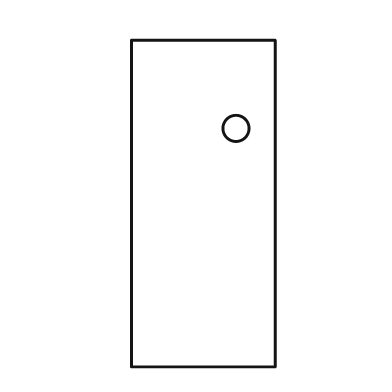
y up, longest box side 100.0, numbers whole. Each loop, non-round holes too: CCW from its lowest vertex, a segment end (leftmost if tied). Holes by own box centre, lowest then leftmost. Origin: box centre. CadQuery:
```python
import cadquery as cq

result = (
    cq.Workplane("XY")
    .moveTo(-22.0, -50.0)
    .lineTo(22.0, -50.0)
    .lineTo(22.0, 50.0)
    .lineTo(-22.0, 50.0)
    .close()
    .moveTo(10.0, 23.0)
    .circle(4.0)
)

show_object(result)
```